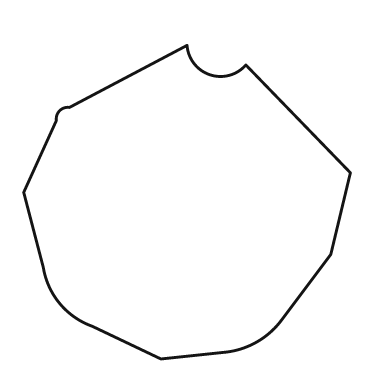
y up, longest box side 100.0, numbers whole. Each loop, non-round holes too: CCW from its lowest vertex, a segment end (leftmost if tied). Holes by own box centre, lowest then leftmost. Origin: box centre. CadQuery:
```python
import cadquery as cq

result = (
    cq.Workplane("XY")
    .moveTo(-8.0, -48.0)
    .lineTo(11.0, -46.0)
    .threePointArc((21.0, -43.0), (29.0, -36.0))
    .lineTo(44.0, -16.0)
    .lineTo(50.0, 9.0)
    .lineTo(18.0, 42.0)
    .threePointArc((7.0, 39.0), (0.0, 48.0))
    .lineTo(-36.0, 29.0)
    .threePointArc((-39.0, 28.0), (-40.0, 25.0))
    .lineTo(-50.0, 3.0)
    .lineTo(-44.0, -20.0)
    .threePointArc((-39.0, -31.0), (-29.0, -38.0))
    .close()
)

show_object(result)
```